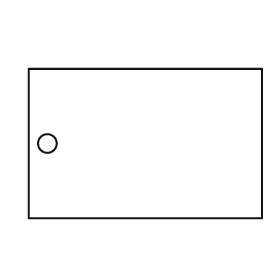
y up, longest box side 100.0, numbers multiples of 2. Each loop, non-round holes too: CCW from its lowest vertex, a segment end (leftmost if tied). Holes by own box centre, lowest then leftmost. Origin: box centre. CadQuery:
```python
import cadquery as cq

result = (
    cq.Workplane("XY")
    .moveTo(-50.0, -32.0)
    .lineTo(50.0, -32.0)
    .lineTo(50.0, 32.0)
    .lineTo(-50.0, 32.0)
    .close()
    .moveTo(-42.0, 0.0)
    .circle(4.0)
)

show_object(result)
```